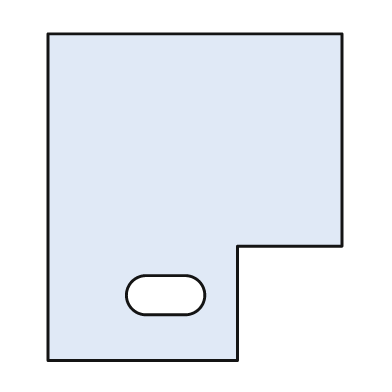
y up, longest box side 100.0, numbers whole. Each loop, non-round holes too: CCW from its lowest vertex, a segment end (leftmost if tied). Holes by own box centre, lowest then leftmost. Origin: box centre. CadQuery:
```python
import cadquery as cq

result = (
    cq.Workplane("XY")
    .moveTo(-45.0, -50.0)
    .lineTo(13.0, -50.0)
    .lineTo(13.0, -15.0)
    .lineTo(45.0, -15.0)
    .lineTo(45.0, 50.0)
    .lineTo(-45.0, 50.0)
    .close()
    .moveTo(-15.0, -36.0)
    .lineTo(-3.0, -36.0)
    .threePointArc((3.0, -30.0), (-3.0, -24.0))
    .lineTo(-15.0, -24.0)
    .threePointArc((-21.0, -30.0), (-15.0, -36.0))
    .close()
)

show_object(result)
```